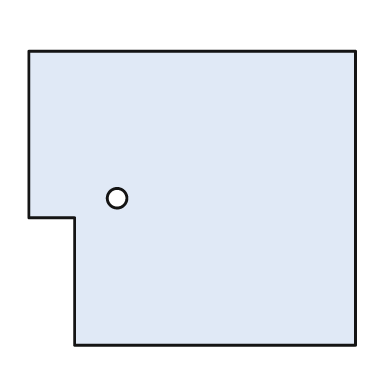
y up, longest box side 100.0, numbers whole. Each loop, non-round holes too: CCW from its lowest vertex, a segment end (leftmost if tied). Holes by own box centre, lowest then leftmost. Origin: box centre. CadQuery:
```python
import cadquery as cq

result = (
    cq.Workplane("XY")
    .moveTo(-36.0, -45.0)
    .lineTo(50.0, -45.0)
    .lineTo(50.0, 45.0)
    .lineTo(-50.0, 45.0)
    .lineTo(-50.0, -6.0)
    .lineTo(-36.0, -6.0)
    .close()
    .moveTo(-23.0, 0.0)
    .circle(3.0)
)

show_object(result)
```